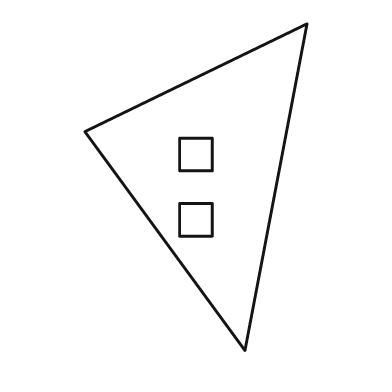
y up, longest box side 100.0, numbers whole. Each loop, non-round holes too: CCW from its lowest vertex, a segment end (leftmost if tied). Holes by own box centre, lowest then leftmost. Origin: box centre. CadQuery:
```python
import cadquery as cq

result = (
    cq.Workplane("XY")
    .moveTo(15.0, -50.0)
    .lineTo(34.0, 50.0)
    .lineTo(-34.0, 17.0)
    .close()
    .moveTo(-5.0, -15.0)
    .lineTo(5.0, -15.0)
    .lineTo(5.0, -5.0)
    .lineTo(-5.0, -5.0)
    .close()
    .moveTo(-5.0, 5.0)
    .lineTo(5.0, 5.0)
    .lineTo(5.0, 15.0)
    .lineTo(-5.0, 15.0)
    .close()
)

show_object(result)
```